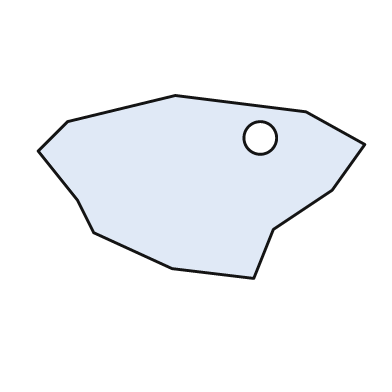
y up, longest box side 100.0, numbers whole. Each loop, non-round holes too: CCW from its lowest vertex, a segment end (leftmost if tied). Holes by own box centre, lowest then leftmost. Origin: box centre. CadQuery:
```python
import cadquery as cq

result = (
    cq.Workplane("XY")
    .moveTo(16.0, -28.0)
    .lineTo(22.0, -13.0)
    .lineTo(40.0, -1.0)
    .lineTo(50.0, 13.0)
    .lineTo(32.0, 23.0)
    .lineTo(-8.0, 28.0)
    .lineTo(-41.0, 20.0)
    .lineTo(-50.0, 11.0)
    .lineTo(-38.0, -4.0)
    .lineTo(-33.0, -14.0)
    .lineTo(-9.0, -25.0)
    .close()
    .moveTo(18.0, 15.0)
    .circle(5.0)
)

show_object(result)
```